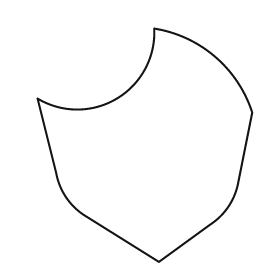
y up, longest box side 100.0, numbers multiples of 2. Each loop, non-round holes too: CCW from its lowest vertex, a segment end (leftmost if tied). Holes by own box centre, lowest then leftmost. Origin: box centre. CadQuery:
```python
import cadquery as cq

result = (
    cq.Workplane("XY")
    .moveTo(6.0, -50.0)
    .lineTo(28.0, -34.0)
    .threePointArc((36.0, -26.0), (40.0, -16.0))
    .lineTo(46.0, 14.0)
    .threePointArc((30.0, 38.0), (4.0, 50.0))
    .threePointArc((-12.0, 20.0), (-46.0, 20.0))
    .lineTo(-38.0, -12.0)
    .threePointArc((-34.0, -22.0), (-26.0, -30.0))
    .close()
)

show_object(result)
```